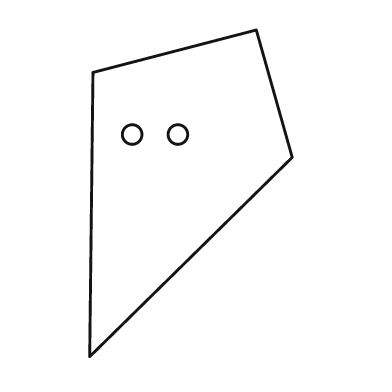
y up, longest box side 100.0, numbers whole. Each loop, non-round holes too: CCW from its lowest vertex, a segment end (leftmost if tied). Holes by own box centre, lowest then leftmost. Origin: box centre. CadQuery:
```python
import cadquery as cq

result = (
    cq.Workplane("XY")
    .moveTo(-31.0, -50.0)
    .lineTo(31.0, 11.0)
    .lineTo(20.0, 50.0)
    .lineTo(-30.0, 37.0)
    .close()
    .moveTo(-18.0, 18.0)
    .circle(3.0)
    .moveTo(-4.0, 18.0)
    .circle(3.0)
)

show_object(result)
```